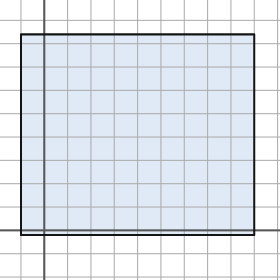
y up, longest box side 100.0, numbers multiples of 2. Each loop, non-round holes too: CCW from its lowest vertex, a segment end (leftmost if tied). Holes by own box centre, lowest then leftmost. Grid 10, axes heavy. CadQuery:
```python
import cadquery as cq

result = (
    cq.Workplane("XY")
    .moveTo(-10.0, -2.0)
    .lineTo(90.0, -2.0)
    .lineTo(90.0, 84.0)
    .lineTo(-10.0, 84.0)
    .close()
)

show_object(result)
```